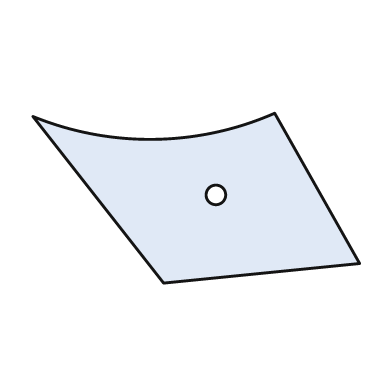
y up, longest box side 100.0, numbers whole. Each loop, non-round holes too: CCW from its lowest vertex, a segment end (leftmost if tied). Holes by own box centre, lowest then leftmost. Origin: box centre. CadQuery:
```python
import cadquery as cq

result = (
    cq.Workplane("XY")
    .moveTo(-10.0, -26.0)
    .lineTo(50.0, -20.0)
    .lineTo(24.0, 26.0)
    .threePointArc((-13.0, 18.0), (-50.0, 25.0))
    .close()
    .moveTo(6.0, 1.0)
    .circle(3.0)
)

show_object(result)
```